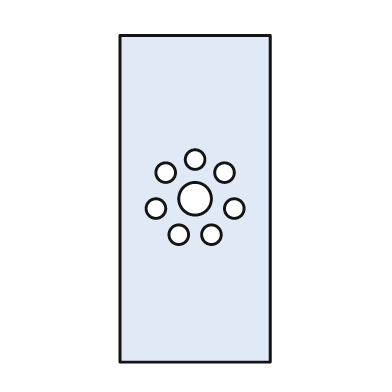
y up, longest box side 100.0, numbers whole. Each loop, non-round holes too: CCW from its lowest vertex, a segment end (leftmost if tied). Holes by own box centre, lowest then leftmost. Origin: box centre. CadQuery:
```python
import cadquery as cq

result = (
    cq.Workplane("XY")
    .moveTo(-23.0, -50.0)
    .lineTo(23.0, -50.0)
    .lineTo(23.0, 50.0)
    .lineTo(-23.0, 50.0)
    .close()
    .moveTo(-5.0, -11.0)
    .circle(3.0)
    .moveTo(5.0, -11.0)
    .circle(3.0)
    .moveTo(-12.0, -3.0)
    .circle(3.0)
    .moveTo(12.0, -3.0)
    .circle(3.0)
    .moveTo(0.0, 0.0)
    .circle(5.0)
    .moveTo(-9.0, 8.0)
    .circle(3.0)
    .moveTo(9.0, 8.0)
    .circle(3.0)
    .moveTo(0.0, 12.0)
    .circle(3.0)
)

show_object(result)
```